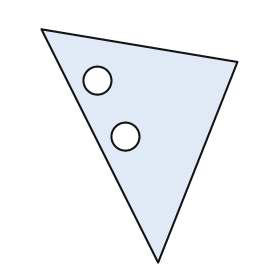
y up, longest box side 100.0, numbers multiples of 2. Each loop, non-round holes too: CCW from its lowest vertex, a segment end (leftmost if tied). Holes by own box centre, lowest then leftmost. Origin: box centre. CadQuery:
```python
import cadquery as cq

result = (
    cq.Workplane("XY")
    .moveTo(8.0, -50.0)
    .lineTo(42.0, 36.0)
    .lineTo(-42.0, 50.0)
    .close()
    .moveTo(-6.0, 4.0)
    .circle(6.0)
    .moveTo(-18.0, 28.0)
    .circle(6.0)
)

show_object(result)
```